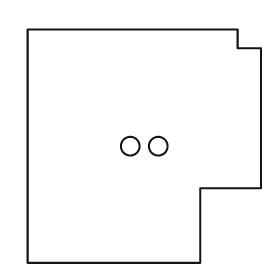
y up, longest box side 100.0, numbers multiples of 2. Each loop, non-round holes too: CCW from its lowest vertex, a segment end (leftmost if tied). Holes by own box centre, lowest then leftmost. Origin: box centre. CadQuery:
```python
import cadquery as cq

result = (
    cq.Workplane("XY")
    .moveTo(-50.0, -50.0)
    .lineTo(24.0, -50.0)
    .lineTo(24.0, -18.0)
    .lineTo(50.0, -18.0)
    .lineTo(50.0, 42.0)
    .lineTo(40.0, 42.0)
    .lineTo(40.0, 50.0)
    .lineTo(-50.0, 50.0)
    .close()
    .moveTo(-6.0, 0.0)
    .circle(4.0)
    .moveTo(6.0, 0.0)
    .circle(4.0)
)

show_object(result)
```